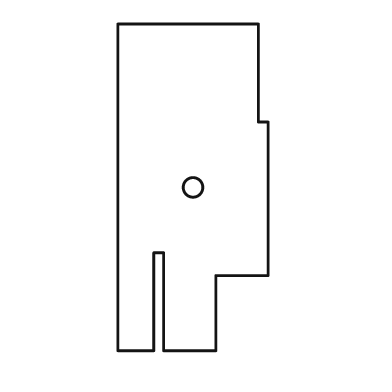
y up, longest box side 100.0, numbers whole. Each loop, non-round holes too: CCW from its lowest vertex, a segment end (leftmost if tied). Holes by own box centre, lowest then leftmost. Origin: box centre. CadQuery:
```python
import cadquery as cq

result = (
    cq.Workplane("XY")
    .moveTo(-23.0, -50.0)
    .lineTo(-12.0, -50.0)
    .lineTo(-12.0, -20.0)
    .lineTo(-9.0, -20.0)
    .lineTo(-9.0, -50.0)
    .lineTo(7.0, -50.0)
    .lineTo(7.0, -27.0)
    .lineTo(23.0, -27.0)
    .lineTo(23.0, 20.0)
    .lineTo(20.0, 20.0)
    .lineTo(20.0, 50.0)
    .lineTo(-23.0, 50.0)
    .close()
    .moveTo(0.0, 0.0)
    .circle(3.0)
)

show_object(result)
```